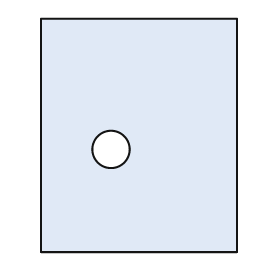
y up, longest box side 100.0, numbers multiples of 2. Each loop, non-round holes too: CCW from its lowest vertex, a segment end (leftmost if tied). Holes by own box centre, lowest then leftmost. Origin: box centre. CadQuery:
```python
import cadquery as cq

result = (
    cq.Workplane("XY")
    .moveTo(-42.0, -50.0)
    .lineTo(42.0, -50.0)
    .lineTo(42.0, 50.0)
    .lineTo(-42.0, 50.0)
    .close()
    .moveTo(-12.0, -6.0)
    .circle(8.0)
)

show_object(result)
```